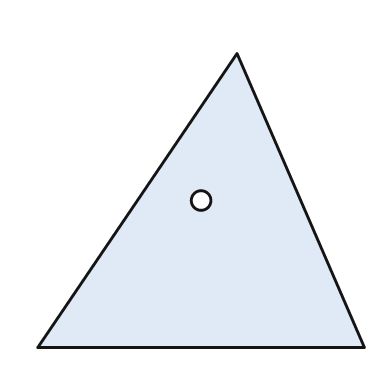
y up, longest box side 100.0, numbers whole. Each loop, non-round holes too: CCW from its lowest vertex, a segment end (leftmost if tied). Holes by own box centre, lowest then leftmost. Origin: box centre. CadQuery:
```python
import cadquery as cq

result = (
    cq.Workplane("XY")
    .moveTo(-50.0, -45.0)
    .lineTo(50.0, -45.0)
    .lineTo(11.0, 45.0)
    .close()
    .moveTo(0.0, 0.0)
    .circle(3.0)
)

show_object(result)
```